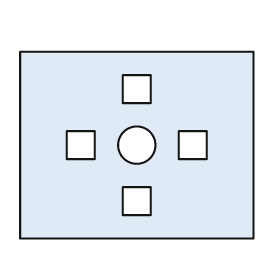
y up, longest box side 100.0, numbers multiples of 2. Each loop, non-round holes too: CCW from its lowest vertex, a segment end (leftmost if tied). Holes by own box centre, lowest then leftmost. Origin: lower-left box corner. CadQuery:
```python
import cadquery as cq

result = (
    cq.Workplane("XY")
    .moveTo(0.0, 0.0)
    .lineTo(100.0, 0.0)
    .lineTo(100.0, 80.0)
    .lineTo(0.0, 80.0)
    .close()
    .moveTo(44.0, 10.0)
    .lineTo(56.0, 10.0)
    .lineTo(56.0, 22.0)
    .lineTo(44.0, 22.0)
    .close()
    .moveTo(20.0, 34.0)
    .lineTo(32.0, 34.0)
    .lineTo(32.0, 46.0)
    .lineTo(20.0, 46.0)
    .close()
    .moveTo(50.0, 40.0)
    .circle(8.0)
    .moveTo(68.0, 34.0)
    .lineTo(80.0, 34.0)
    .lineTo(80.0, 46.0)
    .lineTo(68.0, 46.0)
    .close()
    .moveTo(44.0, 58.0)
    .lineTo(56.0, 58.0)
    .lineTo(56.0, 70.0)
    .lineTo(44.0, 70.0)
    .close()
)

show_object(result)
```